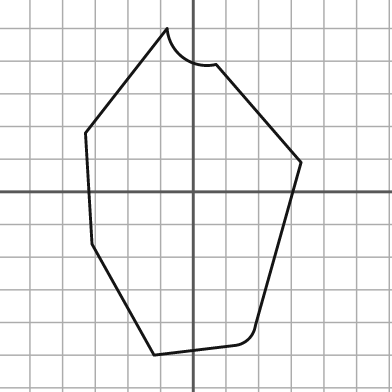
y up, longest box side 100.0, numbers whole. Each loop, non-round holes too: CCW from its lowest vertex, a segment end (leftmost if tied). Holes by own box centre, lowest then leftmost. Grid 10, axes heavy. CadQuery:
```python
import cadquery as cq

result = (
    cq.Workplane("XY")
    .moveTo(-12.0, -50.0)
    .lineTo(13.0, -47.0)
    .threePointArc((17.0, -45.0), (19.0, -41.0))
    .lineTo(33.0, 9.0)
    .lineTo(7.0, 39.0)
    .threePointArc((-3.0, 41.0), (-8.0, 50.0))
    .lineTo(-33.0, 18.0)
    .lineTo(-31.0, -16.0)
    .close()
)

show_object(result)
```